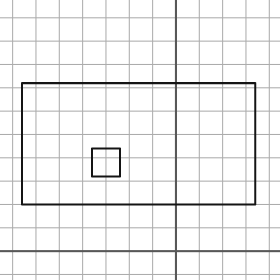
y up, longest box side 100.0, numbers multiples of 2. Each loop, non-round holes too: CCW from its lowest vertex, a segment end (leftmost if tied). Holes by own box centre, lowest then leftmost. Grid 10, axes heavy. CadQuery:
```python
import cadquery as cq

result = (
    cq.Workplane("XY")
    .moveTo(-66.0, 20.0)
    .lineTo(34.0, 20.0)
    .lineTo(34.0, 72.0)
    .lineTo(-66.0, 72.0)
    .close()
    .moveTo(-36.0, 32.0)
    .lineTo(-24.0, 32.0)
    .lineTo(-24.0, 44.0)
    .lineTo(-36.0, 44.0)
    .close()
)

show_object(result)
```